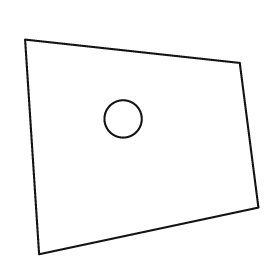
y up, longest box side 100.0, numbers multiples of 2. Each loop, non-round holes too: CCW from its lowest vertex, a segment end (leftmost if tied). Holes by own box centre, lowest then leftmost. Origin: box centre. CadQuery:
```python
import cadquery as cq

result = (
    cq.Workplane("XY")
    .moveTo(-44.0, -46.0)
    .lineTo(50.0, -26.0)
    .lineTo(42.0, 36.0)
    .lineTo(-50.0, 46.0)
    .close()
    .moveTo(-8.0, 12.0)
    .circle(8.0)
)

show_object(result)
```